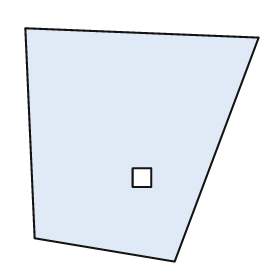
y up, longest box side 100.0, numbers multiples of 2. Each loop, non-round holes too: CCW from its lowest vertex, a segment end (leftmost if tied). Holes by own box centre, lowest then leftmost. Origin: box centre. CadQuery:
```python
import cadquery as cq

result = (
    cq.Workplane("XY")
    .moveTo(14.0, -50.0)
    .lineTo(50.0, 46.0)
    .lineTo(-50.0, 50.0)
    .lineTo(-46.0, -40.0)
    .close()
    .moveTo(-4.0, -18.0)
    .lineTo(4.0, -18.0)
    .lineTo(4.0, -10.0)
    .lineTo(-4.0, -10.0)
    .close()
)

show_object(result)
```